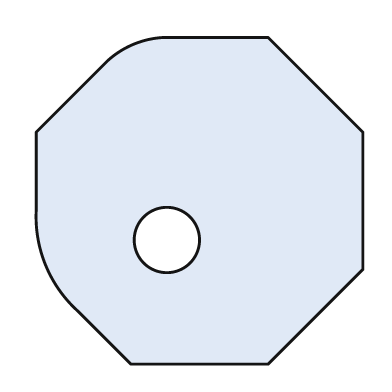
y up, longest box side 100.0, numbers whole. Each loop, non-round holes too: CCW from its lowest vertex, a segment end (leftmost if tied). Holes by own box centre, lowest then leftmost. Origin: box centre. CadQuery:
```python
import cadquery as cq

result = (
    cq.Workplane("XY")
    .moveTo(-21.0, -50.0)
    .lineTo(21.0, -50.0)
    .lineTo(50.0, -21.0)
    .lineTo(50.0, 21.0)
    .lineTo(21.0, 50.0)
    .lineTo(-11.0, 50.0)
    .threePointArc((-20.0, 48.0), (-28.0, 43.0))
    .lineTo(-50.0, 21.0)
    .lineTo(-50.0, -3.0)
    .threePointArc((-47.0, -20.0), (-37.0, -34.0))
    .close()
    .moveTo(-10.0, -12.0)
    .circle(10.0)
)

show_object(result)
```